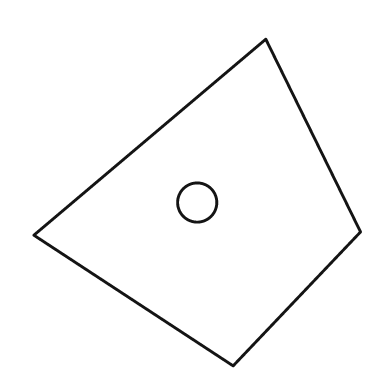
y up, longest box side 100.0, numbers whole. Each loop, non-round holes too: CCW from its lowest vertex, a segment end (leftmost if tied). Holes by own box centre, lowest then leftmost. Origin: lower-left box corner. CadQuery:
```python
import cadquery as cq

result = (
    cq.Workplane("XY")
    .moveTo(61.0, 0.0)
    .lineTo(100.0, 41.0)
    .lineTo(71.0, 100.0)
    .lineTo(0.0, 40.0)
    .close()
    .moveTo(50.0, 50.0)
    .circle(6.0)
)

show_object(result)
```